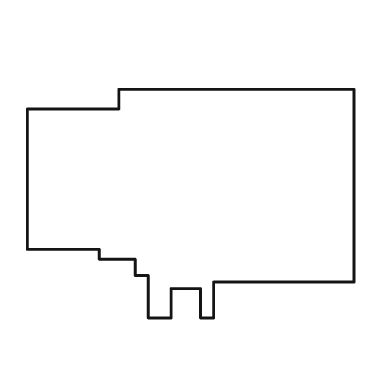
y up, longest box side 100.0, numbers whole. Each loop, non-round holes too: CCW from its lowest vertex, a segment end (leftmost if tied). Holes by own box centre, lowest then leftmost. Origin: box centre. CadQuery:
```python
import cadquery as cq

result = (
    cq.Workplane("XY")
    .moveTo(-13.0, -35.0)
    .lineTo(-6.0, -35.0)
    .lineTo(-6.0, -26.0)
    .lineTo(3.0, -26.0)
    .lineTo(3.0, -35.0)
    .lineTo(7.0, -35.0)
    .lineTo(7.0, -24.0)
    .lineTo(50.0, -24.0)
    .lineTo(50.0, 35.0)
    .lineTo(-22.0, 35.0)
    .lineTo(-22.0, 29.0)
    .lineTo(-50.0, 29.0)
    .lineTo(-50.0, -14.0)
    .lineTo(-28.0, -14.0)
    .lineTo(-28.0, -17.0)
    .lineTo(-17.0, -17.0)
    .lineTo(-17.0, -22.0)
    .lineTo(-13.0, -22.0)
    .close()
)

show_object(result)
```